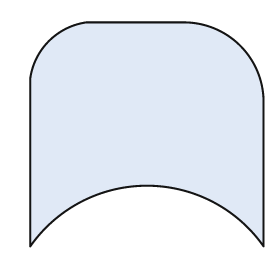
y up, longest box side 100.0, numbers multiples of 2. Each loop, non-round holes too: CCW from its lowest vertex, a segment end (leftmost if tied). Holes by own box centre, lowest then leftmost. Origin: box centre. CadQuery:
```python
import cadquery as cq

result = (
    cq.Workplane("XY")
    .moveTo(-50.0, -48.0)
    .threePointArc((0.0, -22.0), (50.0, -48.0))
    .lineTo(50.0, 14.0)
    .threePointArc((40.0, 38.0), (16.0, 48.0))
    .lineTo(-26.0, 48.0)
    .threePointArc((-42.0, 40.0), (-50.0, 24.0))
    .close()
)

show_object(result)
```